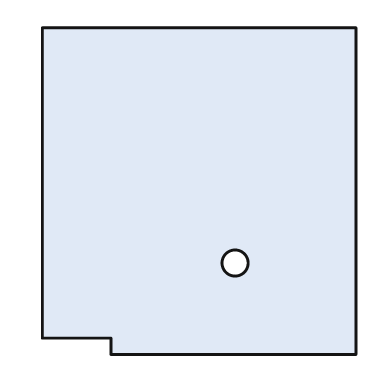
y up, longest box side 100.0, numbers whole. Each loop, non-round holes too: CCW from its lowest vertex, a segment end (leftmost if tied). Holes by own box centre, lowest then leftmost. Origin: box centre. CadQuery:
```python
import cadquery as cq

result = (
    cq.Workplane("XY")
    .moveTo(-27.0, -50.0)
    .lineTo(48.0, -50.0)
    .lineTo(48.0, 50.0)
    .lineTo(-48.0, 50.0)
    .lineTo(-48.0, -45.0)
    .lineTo(-27.0, -45.0)
    .close()
    .moveTo(11.0, -22.0)
    .circle(4.0)
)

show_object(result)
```